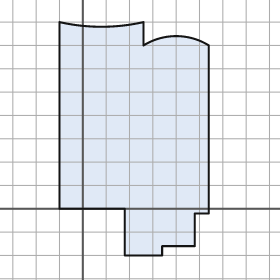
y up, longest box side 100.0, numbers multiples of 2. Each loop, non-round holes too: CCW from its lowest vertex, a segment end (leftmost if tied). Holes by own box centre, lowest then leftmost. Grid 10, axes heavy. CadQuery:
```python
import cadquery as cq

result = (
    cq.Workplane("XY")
    .moveTo(18.0, -20.0)
    .lineTo(34.0, -20.0)
    .lineTo(34.0, -16.0)
    .lineTo(48.0, -16.0)
    .lineTo(48.0, -2.0)
    .lineTo(54.0, -2.0)
    .lineTo(54.0, 70.0)
    .threePointArc((40.0, 74.0), (26.0, 70.0))
    .lineTo(26.0, 80.0)
    .threePointArc((8.0, 78.0), (-10.0, 80.0))
    .lineTo(-10.0, 0.0)
    .lineTo(18.0, 0.0)
    .close()
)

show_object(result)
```